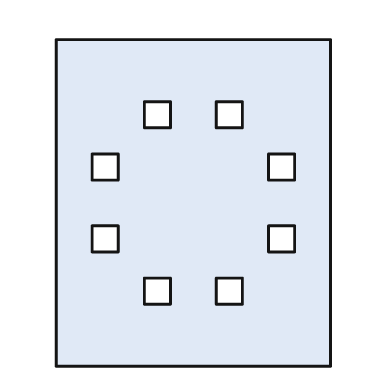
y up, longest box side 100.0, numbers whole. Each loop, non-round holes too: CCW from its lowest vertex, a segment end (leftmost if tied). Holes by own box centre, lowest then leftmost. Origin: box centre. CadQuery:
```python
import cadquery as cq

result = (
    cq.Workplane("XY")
    .moveTo(-42.0, -50.0)
    .lineTo(42.0, -50.0)
    .lineTo(42.0, 50.0)
    .lineTo(-42.0, 50.0)
    .close()
    .moveTo(-15.0, -31.0)
    .lineTo(-7.0, -31.0)
    .lineTo(-7.0, -23.0)
    .lineTo(-15.0, -23.0)
    .close()
    .moveTo(7.0, -31.0)
    .lineTo(15.0, -31.0)
    .lineTo(15.0, -23.0)
    .lineTo(7.0, -23.0)
    .close()
    .moveTo(-31.0, -15.0)
    .lineTo(-23.0, -15.0)
    .lineTo(-23.0, -7.0)
    .lineTo(-31.0, -7.0)
    .close()
    .moveTo(23.0, -15.0)
    .lineTo(31.0, -15.0)
    .lineTo(31.0, -7.0)
    .lineTo(23.0, -7.0)
    .close()
    .moveTo(-31.0, 7.0)
    .lineTo(-23.0, 7.0)
    .lineTo(-23.0, 15.0)
    .lineTo(-31.0, 15.0)
    .close()
    .moveTo(23.0, 7.0)
    .lineTo(31.0, 7.0)
    .lineTo(31.0, 15.0)
    .lineTo(23.0, 15.0)
    .close()
    .moveTo(-15.0, 23.0)
    .lineTo(-7.0, 23.0)
    .lineTo(-7.0, 31.0)
    .lineTo(-15.0, 31.0)
    .close()
    .moveTo(7.0, 23.0)
    .lineTo(15.0, 23.0)
    .lineTo(15.0, 31.0)
    .lineTo(7.0, 31.0)
    .close()
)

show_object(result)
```